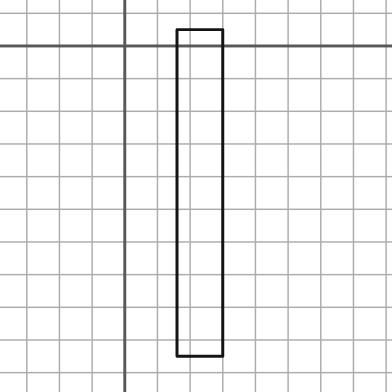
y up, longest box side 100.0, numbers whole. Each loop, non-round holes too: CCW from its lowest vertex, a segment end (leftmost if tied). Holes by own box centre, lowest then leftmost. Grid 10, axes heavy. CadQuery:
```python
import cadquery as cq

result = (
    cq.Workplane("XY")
    .moveTo(16.0, -95.0)
    .lineTo(30.0, -95.0)
    .lineTo(30.0, 5.0)
    .lineTo(16.0, 5.0)
    .close()
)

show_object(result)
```